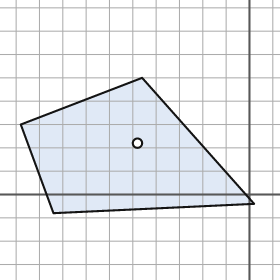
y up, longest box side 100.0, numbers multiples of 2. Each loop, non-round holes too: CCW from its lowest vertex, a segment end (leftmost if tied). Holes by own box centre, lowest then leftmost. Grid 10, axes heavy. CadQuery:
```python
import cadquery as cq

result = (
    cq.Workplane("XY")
    .moveTo(-84.0, -8.0)
    .lineTo(2.0, -4.0)
    .lineTo(-46.0, 50.0)
    .lineTo(-98.0, 30.0)
    .close()
    .moveTo(-48.0, 22.0)
    .circle(2.0)
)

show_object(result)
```